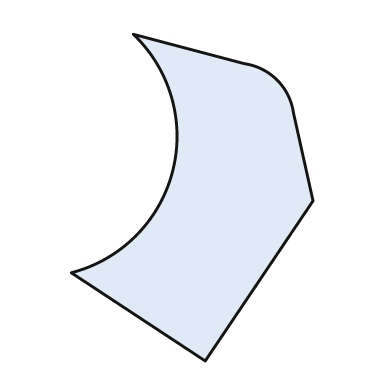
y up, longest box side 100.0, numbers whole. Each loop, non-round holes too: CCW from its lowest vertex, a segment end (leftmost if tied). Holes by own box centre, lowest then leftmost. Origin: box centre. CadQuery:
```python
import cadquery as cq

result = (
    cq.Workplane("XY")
    .moveTo(4.0, -50.0)
    .lineTo(37.0, -1.0)
    .lineTo(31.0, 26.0)
    .threePointArc((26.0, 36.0), (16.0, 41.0))
    .lineTo(-18.0, 50.0)
    .threePointArc((-6.0, 8.0), (-37.0, -23.0))
    .close()
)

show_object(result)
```